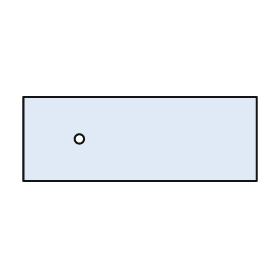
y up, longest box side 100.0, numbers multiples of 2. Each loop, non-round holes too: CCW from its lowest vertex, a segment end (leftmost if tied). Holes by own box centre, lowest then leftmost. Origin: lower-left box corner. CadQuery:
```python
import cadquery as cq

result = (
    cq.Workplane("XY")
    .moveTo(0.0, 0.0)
    .lineTo(100.0, 0.0)
    .lineTo(100.0, 36.0)
    .lineTo(0.0, 36.0)
    .close()
    .moveTo(24.0, 18.0)
    .circle(2.0)
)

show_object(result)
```